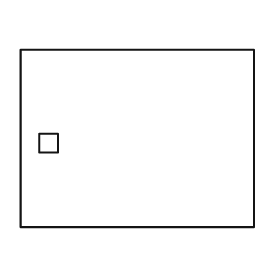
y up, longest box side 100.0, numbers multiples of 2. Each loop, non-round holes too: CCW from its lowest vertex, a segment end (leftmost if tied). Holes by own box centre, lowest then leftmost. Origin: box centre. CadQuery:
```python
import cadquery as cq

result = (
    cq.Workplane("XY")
    .moveTo(-50.0, -38.0)
    .lineTo(50.0, -38.0)
    .lineTo(50.0, 38.0)
    .lineTo(-50.0, 38.0)
    .close()
    .moveTo(-42.0, -6.0)
    .lineTo(-34.0, -6.0)
    .lineTo(-34.0, 2.0)
    .lineTo(-42.0, 2.0)
    .close()
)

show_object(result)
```